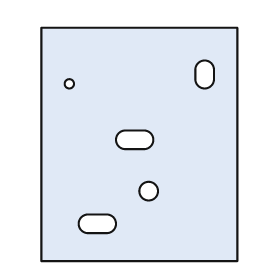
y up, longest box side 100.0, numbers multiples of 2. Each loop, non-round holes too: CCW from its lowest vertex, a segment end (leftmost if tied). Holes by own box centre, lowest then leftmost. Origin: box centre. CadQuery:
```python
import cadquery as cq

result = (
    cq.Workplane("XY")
    .moveTo(-42.0, -50.0)
    .lineTo(42.0, -50.0)
    .lineTo(42.0, 50.0)
    .lineTo(-42.0, 50.0)
    .close()
    .moveTo(-22.0, -38.0)
    .lineTo(-14.0, -38.0)
    .threePointArc((-10.0, -34.0), (-14.0, -30.0))
    .lineTo(-22.0, -30.0)
    .threePointArc((-26.0, -34.0), (-22.0, -38.0))
    .close()
    .moveTo(4.0, -20.0)
    .circle(4.0)
    .moveTo(-6.0, -2.0)
    .lineTo(2.0, -2.0)
    .threePointArc((6.0, 2.0), (2.0, 6.0))
    .lineTo(-6.0, 6.0)
    .threePointArc((-10.0, 2.0), (-6.0, -2.0))
    .close()
    .moveTo(-30.0, 26.0)
    .circle(2.0)
    .moveTo(24.0, 28.0)
    .threePointArc((28.0, 24.0), (32.0, 28.0))
    .lineTo(32.0, 32.0)
    .threePointArc((28.0, 36.0), (24.0, 32.0))
    .close()
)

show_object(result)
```